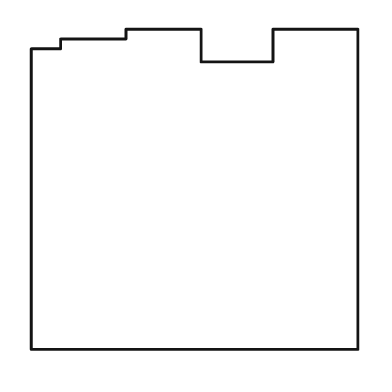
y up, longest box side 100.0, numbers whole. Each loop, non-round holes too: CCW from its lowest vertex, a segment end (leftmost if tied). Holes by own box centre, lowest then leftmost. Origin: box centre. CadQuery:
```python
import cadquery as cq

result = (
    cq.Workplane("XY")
    .moveTo(-50.0, -49.0)
    .lineTo(50.0, -49.0)
    .lineTo(50.0, 49.0)
    .lineTo(24.0, 49.0)
    .lineTo(24.0, 39.0)
    .lineTo(2.0, 39.0)
    .lineTo(2.0, 49.0)
    .lineTo(-21.0, 49.0)
    .lineTo(-21.0, 46.0)
    .lineTo(-41.0, 46.0)
    .lineTo(-41.0, 43.0)
    .lineTo(-50.0, 43.0)
    .close()
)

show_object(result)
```